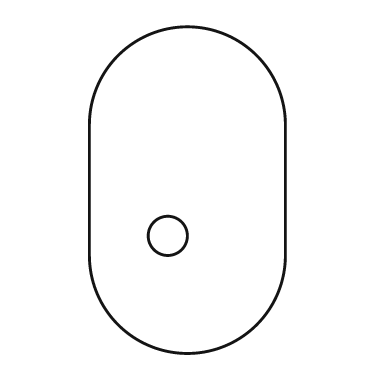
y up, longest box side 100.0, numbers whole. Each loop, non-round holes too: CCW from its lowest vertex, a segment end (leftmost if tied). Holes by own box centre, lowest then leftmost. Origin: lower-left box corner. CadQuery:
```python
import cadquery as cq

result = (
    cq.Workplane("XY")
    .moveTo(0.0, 30.0)
    .threePointArc((30.0, 0.0), (60.0, 30.0))
    .lineTo(60.0, 70.0)
    .threePointArc((30.0, 100.0), (0.0, 70.0))
    .close()
    .moveTo(24.0, 36.0)
    .circle(6.0)
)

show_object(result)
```